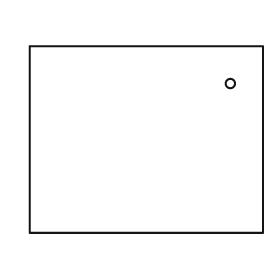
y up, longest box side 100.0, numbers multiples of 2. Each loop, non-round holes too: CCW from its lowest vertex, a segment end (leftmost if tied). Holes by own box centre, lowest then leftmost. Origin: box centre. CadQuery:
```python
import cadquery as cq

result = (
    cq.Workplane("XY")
    .moveTo(-50.0, -40.0)
    .lineTo(50.0, -40.0)
    .lineTo(50.0, 40.0)
    .lineTo(-50.0, 40.0)
    .close()
    .moveTo(36.0, 24.0)
    .circle(2.0)
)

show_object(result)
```